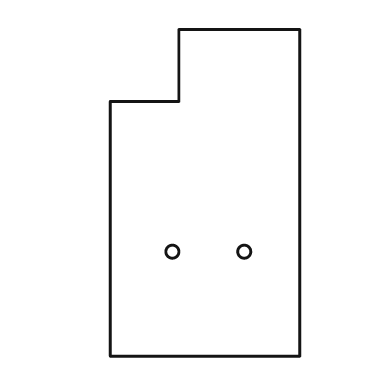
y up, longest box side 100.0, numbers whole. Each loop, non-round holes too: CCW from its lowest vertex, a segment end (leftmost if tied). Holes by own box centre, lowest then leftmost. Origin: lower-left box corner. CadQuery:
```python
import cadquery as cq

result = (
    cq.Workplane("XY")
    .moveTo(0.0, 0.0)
    .lineTo(58.0, 0.0)
    .lineTo(58.0, 100.0)
    .lineTo(21.0, 100.0)
    .lineTo(21.0, 78.0)
    .lineTo(0.0, 78.0)
    .close()
    .moveTo(19.0, 32.0)
    .circle(2.0)
    .moveTo(41.0, 32.0)
    .circle(2.0)
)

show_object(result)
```